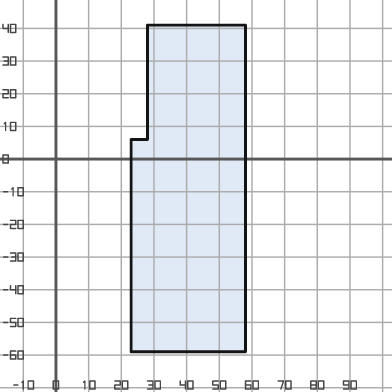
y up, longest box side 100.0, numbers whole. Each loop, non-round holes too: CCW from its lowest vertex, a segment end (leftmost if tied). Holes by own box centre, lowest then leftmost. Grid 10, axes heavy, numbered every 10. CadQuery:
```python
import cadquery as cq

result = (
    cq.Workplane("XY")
    .moveTo(23.0, -59.0)
    .lineTo(58.0, -59.0)
    .lineTo(58.0, 41.0)
    .lineTo(28.0, 41.0)
    .lineTo(28.0, 6.0)
    .lineTo(23.0, 6.0)
    .close()
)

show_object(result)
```